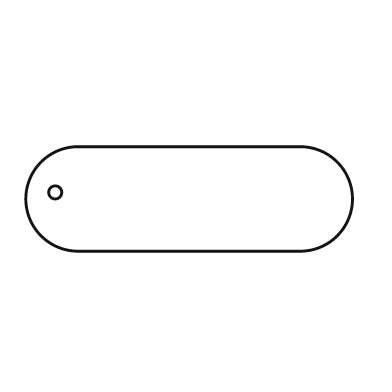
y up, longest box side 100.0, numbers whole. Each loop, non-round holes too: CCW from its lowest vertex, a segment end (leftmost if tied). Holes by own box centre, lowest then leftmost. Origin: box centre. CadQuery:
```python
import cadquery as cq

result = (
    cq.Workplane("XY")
    .moveTo(-34.0, -16.0)
    .lineTo(34.0, -16.0)
    .threePointArc((50.0, 0.0), (34.0, 16.0))
    .lineTo(-34.0, 16.0)
    .threePointArc((-50.0, 0.0), (-34.0, -16.0))
    .close()
    .moveTo(-41.0, 2.0)
    .circle(2.0)
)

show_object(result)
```